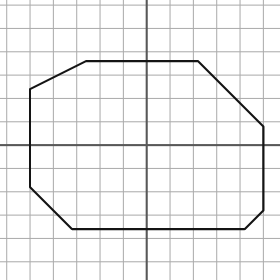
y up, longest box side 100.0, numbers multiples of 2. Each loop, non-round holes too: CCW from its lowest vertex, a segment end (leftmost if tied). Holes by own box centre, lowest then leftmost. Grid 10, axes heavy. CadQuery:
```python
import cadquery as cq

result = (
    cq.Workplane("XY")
    .moveTo(-32.0, -36.0)
    .lineTo(42.0, -36.0)
    .lineTo(50.0, -28.0)
    .lineTo(50.0, 8.0)
    .lineTo(22.0, 36.0)
    .lineTo(-26.0, 36.0)
    .lineTo(-50.0, 24.0)
    .lineTo(-50.0, -18.0)
    .close()
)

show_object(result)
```